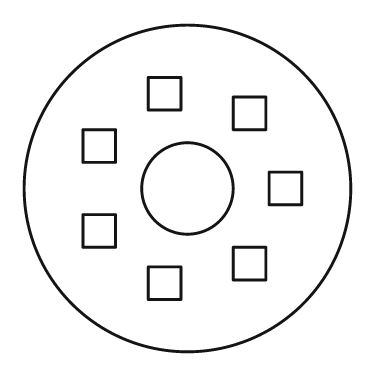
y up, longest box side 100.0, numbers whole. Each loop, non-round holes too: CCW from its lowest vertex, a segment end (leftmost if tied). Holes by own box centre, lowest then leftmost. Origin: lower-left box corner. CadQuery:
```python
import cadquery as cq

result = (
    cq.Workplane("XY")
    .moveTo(50.0, 50.0)
    .circle(50.0)
    .moveTo(38.0, 16.0)
    .lineTo(48.0, 16.0)
    .lineTo(48.0, 26.0)
    .lineTo(38.0, 26.0)
    .close()
    .moveTo(64.0, 22.0)
    .lineTo(74.0, 22.0)
    .lineTo(74.0, 32.0)
    .lineTo(64.0, 32.0)
    .close()
    .moveTo(18.0, 32.0)
    .lineTo(28.0, 32.0)
    .lineTo(28.0, 42.0)
    .lineTo(18.0, 42.0)
    .close()
    .moveTo(50.0, 50.0)
    .circle(14.0)
    .moveTo(75.0, 45.0)
    .lineTo(85.0, 45.0)
    .lineTo(85.0, 55.0)
    .lineTo(75.0, 55.0)
    .close()
    .moveTo(18.0, 58.0)
    .lineTo(28.0, 58.0)
    .lineTo(28.0, 68.0)
    .lineTo(18.0, 68.0)
    .close()
    .moveTo(64.0, 68.0)
    .lineTo(74.0, 68.0)
    .lineTo(74.0, 78.0)
    .lineTo(64.0, 78.0)
    .close()
    .moveTo(38.0, 74.0)
    .lineTo(48.0, 74.0)
    .lineTo(48.0, 84.0)
    .lineTo(38.0, 84.0)
    .close()
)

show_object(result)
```